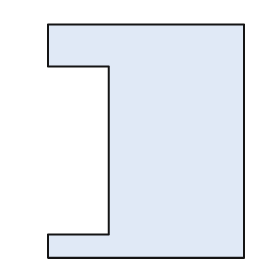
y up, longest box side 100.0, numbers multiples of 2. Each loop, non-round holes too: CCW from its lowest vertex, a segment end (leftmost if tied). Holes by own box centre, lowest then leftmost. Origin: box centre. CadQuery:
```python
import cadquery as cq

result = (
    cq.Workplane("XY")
    .moveTo(-42.0, -50.0)
    .lineTo(42.0, -50.0)
    .lineTo(42.0, 50.0)
    .lineTo(-42.0, 50.0)
    .lineTo(-42.0, 32.0)
    .lineTo(-16.0, 32.0)
    .lineTo(-16.0, -40.0)
    .lineTo(-42.0, -40.0)
    .close()
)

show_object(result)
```